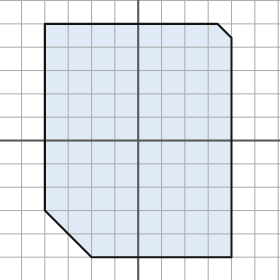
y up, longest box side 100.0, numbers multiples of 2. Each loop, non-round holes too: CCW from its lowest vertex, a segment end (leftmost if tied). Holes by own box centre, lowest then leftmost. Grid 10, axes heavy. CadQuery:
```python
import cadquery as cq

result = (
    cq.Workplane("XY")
    .moveTo(-20.0, -50.0)
    .lineTo(40.0, -50.0)
    .lineTo(40.0, 44.0)
    .lineTo(34.0, 50.0)
    .lineTo(-40.0, 50.0)
    .lineTo(-40.0, -30.0)
    .close()
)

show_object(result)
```